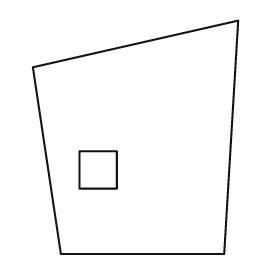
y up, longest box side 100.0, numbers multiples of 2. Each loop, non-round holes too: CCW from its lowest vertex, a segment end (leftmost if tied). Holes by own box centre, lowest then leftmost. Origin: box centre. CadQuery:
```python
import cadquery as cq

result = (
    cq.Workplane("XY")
    .moveTo(-32.0, -50.0)
    .lineTo(38.0, -50.0)
    .lineTo(44.0, 50.0)
    .lineTo(-44.0, 30.0)
    .close()
    .moveTo(-24.0, -22.0)
    .lineTo(-8.0, -22.0)
    .lineTo(-8.0, -6.0)
    .lineTo(-24.0, -6.0)
    .close()
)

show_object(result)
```